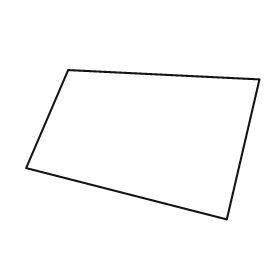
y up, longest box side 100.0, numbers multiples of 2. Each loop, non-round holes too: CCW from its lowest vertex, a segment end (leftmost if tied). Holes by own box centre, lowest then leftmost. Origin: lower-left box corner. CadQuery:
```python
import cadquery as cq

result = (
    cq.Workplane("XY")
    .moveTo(86.0, 0.0)
    .lineTo(100.0, 60.0)
    .lineTo(18.0, 64.0)
    .lineTo(0.0, 22.0)
    .close()
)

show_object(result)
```